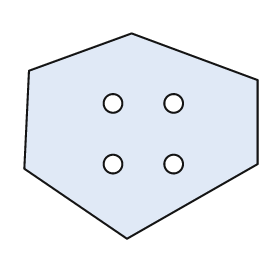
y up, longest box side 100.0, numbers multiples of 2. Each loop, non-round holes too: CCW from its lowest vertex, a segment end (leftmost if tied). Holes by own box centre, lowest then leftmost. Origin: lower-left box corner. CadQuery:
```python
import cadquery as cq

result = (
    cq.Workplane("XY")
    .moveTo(44.0, 0.0)
    .lineTo(100.0, 32.0)
    .lineTo(100.0, 68.0)
    .lineTo(46.0, 88.0)
    .lineTo(2.0, 72.0)
    .lineTo(0.0, 30.0)
    .close()
    .moveTo(38.0, 32.0)
    .circle(4.0)
    .moveTo(64.0, 32.0)
    .circle(4.0)
    .moveTo(38.0, 58.0)
    .circle(4.0)
    .moveTo(64.0, 58.0)
    .circle(4.0)
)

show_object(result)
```